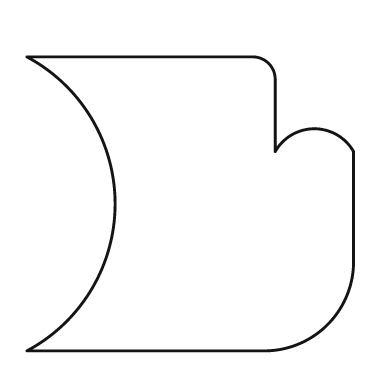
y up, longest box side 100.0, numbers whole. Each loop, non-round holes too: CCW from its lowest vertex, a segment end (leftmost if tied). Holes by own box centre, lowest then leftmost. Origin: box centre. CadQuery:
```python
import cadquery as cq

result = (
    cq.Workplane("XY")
    .moveTo(-50.0, -45.0)
    .lineTo(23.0, -45.0)
    .threePointArc((42.0, -37.0), (50.0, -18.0))
    .lineTo(50.0, 16.0)
    .threePointArc((38.0, 23.0), (26.0, 16.0))
    .lineTo(26.0, 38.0)
    .threePointArc((24.0, 43.0), (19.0, 45.0))
    .lineTo(-50.0, 45.0)
    .threePointArc((-23.0, 0.0), (-50.0, -45.0))
    .close()
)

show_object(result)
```